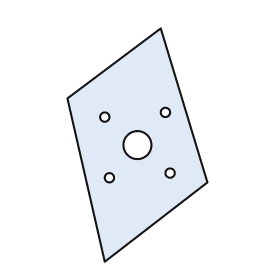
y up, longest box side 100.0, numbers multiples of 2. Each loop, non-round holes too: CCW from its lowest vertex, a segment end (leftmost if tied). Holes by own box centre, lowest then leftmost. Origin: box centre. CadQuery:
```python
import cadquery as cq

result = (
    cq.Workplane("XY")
    .moveTo(-14.0, -50.0)
    .lineTo(30.0, -16.0)
    .lineTo(10.0, 50.0)
    .lineTo(-30.0, 20.0)
    .close()
    .moveTo(-12.0, -14.0)
    .circle(2.0)
    .moveTo(14.0, -12.0)
    .circle(2.0)
    .moveTo(0.0, 0.0)
    .circle(6.0)
    .moveTo(-14.0, 12.0)
    .circle(2.0)
    .moveTo(12.0, 14.0)
    .circle(2.0)
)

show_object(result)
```